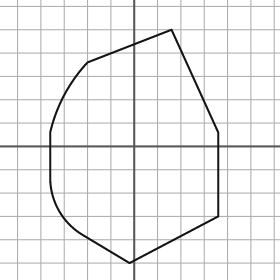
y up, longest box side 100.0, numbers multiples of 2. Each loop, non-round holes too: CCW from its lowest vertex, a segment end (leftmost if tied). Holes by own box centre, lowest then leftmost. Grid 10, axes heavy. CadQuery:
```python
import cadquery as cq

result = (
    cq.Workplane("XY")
    .moveTo(-2.0, -50.0)
    .lineTo(36.0, -30.0)
    .lineTo(36.0, 6.0)
    .lineTo(16.0, 50.0)
    .lineTo(-20.0, 36.0)
    .threePointArc((-30.0, 22.0), (-36.0, 6.0))
    .lineTo(-36.0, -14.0)
    .threePointArc((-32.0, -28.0), (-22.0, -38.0))
    .close()
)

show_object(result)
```